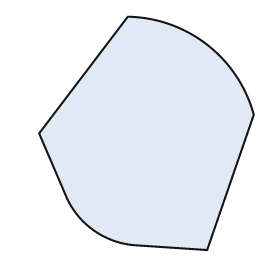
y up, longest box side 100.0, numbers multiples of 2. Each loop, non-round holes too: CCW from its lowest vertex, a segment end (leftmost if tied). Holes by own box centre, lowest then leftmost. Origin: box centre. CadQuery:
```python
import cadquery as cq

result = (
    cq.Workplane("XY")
    .moveTo(26.0, -50.0)
    .lineTo(46.0, 8.0)
    .threePointArc((26.0, 38.0), (-8.0, 50.0))
    .lineTo(-46.0, 0.0)
    .lineTo(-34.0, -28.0)
    .threePointArc((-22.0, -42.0), (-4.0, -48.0))
    .close()
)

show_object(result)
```